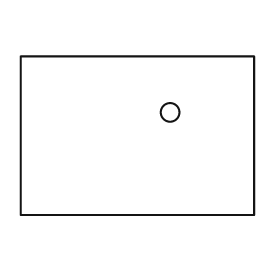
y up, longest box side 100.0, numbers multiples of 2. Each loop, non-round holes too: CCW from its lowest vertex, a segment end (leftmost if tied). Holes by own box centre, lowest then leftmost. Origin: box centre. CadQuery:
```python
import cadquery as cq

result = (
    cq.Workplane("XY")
    .moveTo(-50.0, -34.0)
    .lineTo(50.0, -34.0)
    .lineTo(50.0, 34.0)
    .lineTo(-50.0, 34.0)
    .close()
    .moveTo(14.0, 10.0)
    .circle(4.0)
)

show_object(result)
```